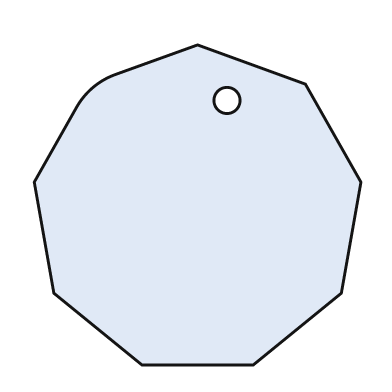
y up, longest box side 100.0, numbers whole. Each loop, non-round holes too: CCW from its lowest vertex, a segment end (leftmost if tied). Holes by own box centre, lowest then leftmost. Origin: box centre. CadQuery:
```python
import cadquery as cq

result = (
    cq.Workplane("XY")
    .moveTo(-17.0, -49.0)
    .lineTo(17.0, -49.0)
    .lineTo(44.0, -27.0)
    .lineTo(50.0, 7.0)
    .lineTo(33.0, 37.0)
    .lineTo(0.0, 49.0)
    .lineTo(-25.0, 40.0)
    .threePointArc((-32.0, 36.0), (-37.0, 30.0))
    .lineTo(-50.0, 7.0)
    .lineTo(-44.0, -27.0)
    .close()
    .moveTo(9.0, 32.0)
    .circle(4.0)
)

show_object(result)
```